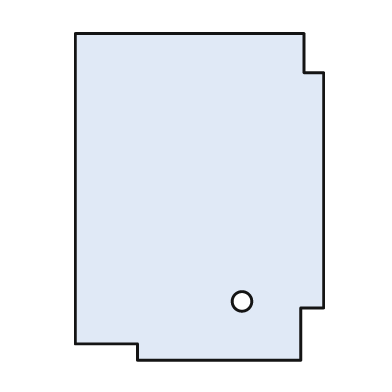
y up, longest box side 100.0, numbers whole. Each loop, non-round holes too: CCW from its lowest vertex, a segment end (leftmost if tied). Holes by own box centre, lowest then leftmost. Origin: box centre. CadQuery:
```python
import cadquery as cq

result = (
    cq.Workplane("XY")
    .moveTo(-19.0, -50.0)
    .lineTo(31.0, -50.0)
    .lineTo(31.0, -34.0)
    .lineTo(38.0, -34.0)
    .lineTo(38.0, 38.0)
    .lineTo(32.0, 38.0)
    .lineTo(32.0, 50.0)
    .lineTo(-38.0, 50.0)
    .lineTo(-38.0, -45.0)
    .lineTo(-19.0, -45.0)
    .close()
    .moveTo(13.0, -32.0)
    .circle(3.0)
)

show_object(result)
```